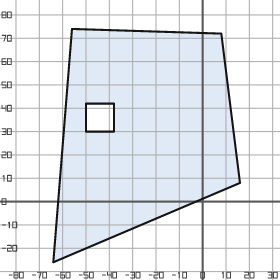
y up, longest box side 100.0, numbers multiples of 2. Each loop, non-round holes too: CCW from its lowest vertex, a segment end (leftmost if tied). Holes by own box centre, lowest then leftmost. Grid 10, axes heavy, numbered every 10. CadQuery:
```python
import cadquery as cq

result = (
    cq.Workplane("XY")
    .moveTo(-64.0, -26.0)
    .lineTo(16.0, 8.0)
    .lineTo(8.0, 72.0)
    .lineTo(-56.0, 74.0)
    .close()
    .moveTo(-50.0, 30.0)
    .lineTo(-38.0, 30.0)
    .lineTo(-38.0, 42.0)
    .lineTo(-50.0, 42.0)
    .close()
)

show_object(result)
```